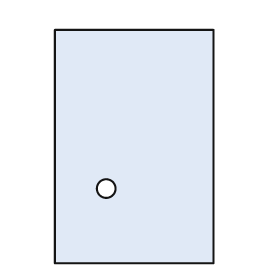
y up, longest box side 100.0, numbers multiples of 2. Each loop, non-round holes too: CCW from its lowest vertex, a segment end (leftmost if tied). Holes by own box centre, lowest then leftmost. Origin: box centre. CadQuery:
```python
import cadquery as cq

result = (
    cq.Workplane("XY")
    .moveTo(-34.0, -50.0)
    .lineTo(34.0, -50.0)
    .lineTo(34.0, 50.0)
    .lineTo(-34.0, 50.0)
    .close()
    .moveTo(-12.0, -18.0)
    .circle(4.0)
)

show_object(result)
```